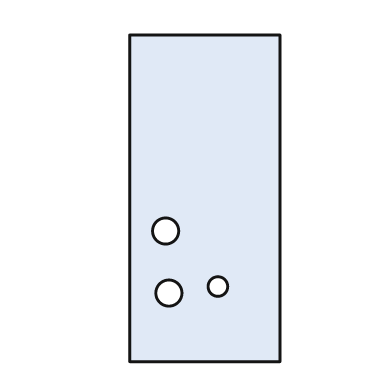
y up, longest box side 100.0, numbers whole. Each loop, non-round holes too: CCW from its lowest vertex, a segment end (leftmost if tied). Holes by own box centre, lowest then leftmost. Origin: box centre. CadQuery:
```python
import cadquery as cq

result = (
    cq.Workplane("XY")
    .moveTo(-23.0, -50.0)
    .lineTo(23.0, -50.0)
    .lineTo(23.0, 50.0)
    .lineTo(-23.0, 50.0)
    .close()
    .moveTo(-11.0, -29.0)
    .circle(4.0)
    .moveTo(4.0, -27.0)
    .circle(3.0)
    .moveTo(-12.0, -10.0)
    .circle(4.0)
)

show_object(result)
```